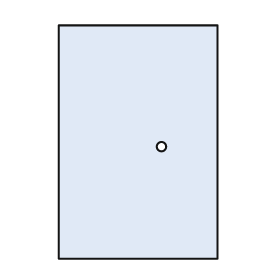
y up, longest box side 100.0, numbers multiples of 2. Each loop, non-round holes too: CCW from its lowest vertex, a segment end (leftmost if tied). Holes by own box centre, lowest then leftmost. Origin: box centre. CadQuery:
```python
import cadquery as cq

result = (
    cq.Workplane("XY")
    .moveTo(-34.0, -50.0)
    .lineTo(34.0, -50.0)
    .lineTo(34.0, 50.0)
    .lineTo(-34.0, 50.0)
    .close()
    .moveTo(10.0, -2.0)
    .circle(2.0)
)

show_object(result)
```